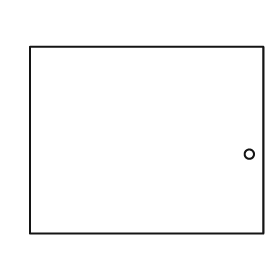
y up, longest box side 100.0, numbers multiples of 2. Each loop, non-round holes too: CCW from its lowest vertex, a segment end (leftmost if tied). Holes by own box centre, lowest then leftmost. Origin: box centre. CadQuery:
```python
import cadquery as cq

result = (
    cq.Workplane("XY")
    .moveTo(-50.0, -40.0)
    .lineTo(50.0, -40.0)
    .lineTo(50.0, 40.0)
    .lineTo(-50.0, 40.0)
    .close()
    .moveTo(44.0, -6.0)
    .circle(2.0)
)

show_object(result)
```